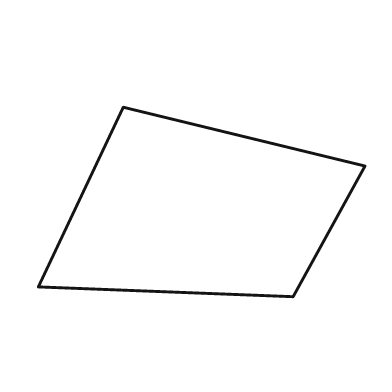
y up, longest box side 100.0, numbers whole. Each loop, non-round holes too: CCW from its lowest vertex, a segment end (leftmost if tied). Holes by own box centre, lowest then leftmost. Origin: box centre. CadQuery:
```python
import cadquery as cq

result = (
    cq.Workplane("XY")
    .moveTo(28.0, -29.0)
    .lineTo(50.0, 11.0)
    .lineTo(-24.0, 29.0)
    .lineTo(-50.0, -26.0)
    .close()
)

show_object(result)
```